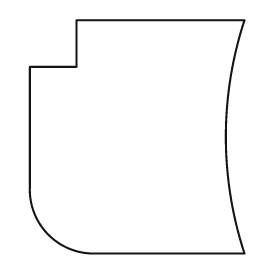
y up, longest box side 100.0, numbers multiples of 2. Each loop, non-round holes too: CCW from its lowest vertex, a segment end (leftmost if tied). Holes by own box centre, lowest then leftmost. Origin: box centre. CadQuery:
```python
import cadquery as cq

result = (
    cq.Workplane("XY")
    .moveTo(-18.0, -50.0)
    .lineTo(46.0, -50.0)
    .threePointArc((38.0, 0.0), (46.0, 50.0))
    .lineTo(-26.0, 50.0)
    .lineTo(-26.0, 30.0)
    .lineTo(-46.0, 30.0)
    .lineTo(-46.0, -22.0)
    .threePointArc((-38.0, -42.0), (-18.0, -50.0))
    .close()
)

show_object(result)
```